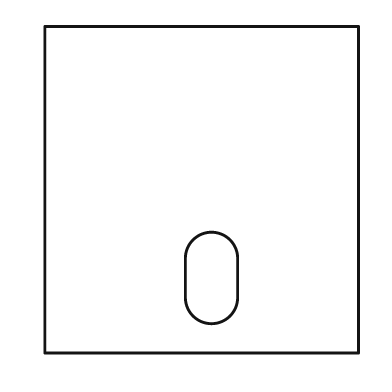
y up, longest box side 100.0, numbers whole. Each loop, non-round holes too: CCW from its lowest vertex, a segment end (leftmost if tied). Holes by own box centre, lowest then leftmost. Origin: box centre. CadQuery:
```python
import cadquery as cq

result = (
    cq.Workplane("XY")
    .moveTo(-48.0, -50.0)
    .lineTo(48.0, -50.0)
    .lineTo(48.0, 50.0)
    .lineTo(-48.0, 50.0)
    .close()
    .moveTo(-5.0, -33.0)
    .threePointArc((3.0, -41.0), (11.0, -33.0))
    .lineTo(11.0, -21.0)
    .threePointArc((3.0, -13.0), (-5.0, -21.0))
    .close()
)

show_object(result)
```